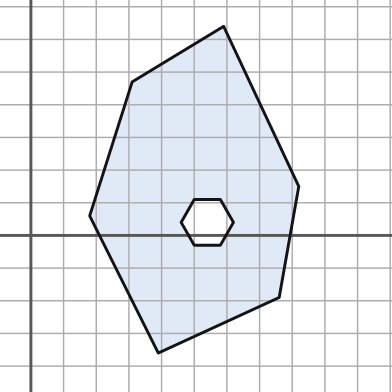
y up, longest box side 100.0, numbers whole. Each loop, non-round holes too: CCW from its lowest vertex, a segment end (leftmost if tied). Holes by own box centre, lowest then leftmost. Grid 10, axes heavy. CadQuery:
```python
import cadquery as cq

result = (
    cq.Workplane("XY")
    .moveTo(39.0, -36.0)
    .lineTo(76.0, -19.0)
    .lineTo(82.0, 15.0)
    .lineTo(59.0, 64.0)
    .lineTo(31.0, 47.0)
    .lineTo(18.0, 6.0)
    .close()
    .moveTo(50.0, -3.0)
    .lineTo(58.0, -3.0)
    .lineTo(62.0, 4.0)
    .lineTo(58.0, 11.0)
    .lineTo(50.0, 11.0)
    .lineTo(46.0, 4.0)
    .close()
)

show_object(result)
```